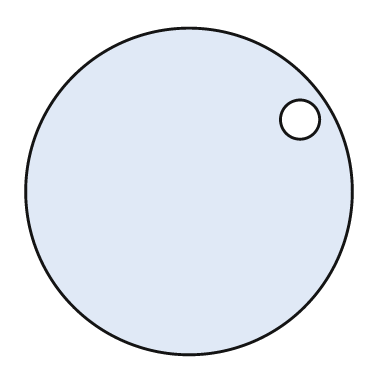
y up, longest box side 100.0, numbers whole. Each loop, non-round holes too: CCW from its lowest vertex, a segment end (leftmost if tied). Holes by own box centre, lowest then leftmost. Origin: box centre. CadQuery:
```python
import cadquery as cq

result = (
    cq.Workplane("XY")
    .moveTo(0.0, 0.0)
    .circle(50.0)
    .moveTo(34.0, 22.0)
    .circle(6.0)
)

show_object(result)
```